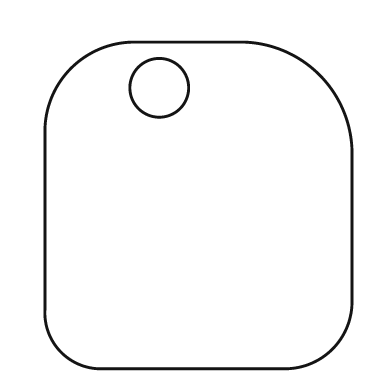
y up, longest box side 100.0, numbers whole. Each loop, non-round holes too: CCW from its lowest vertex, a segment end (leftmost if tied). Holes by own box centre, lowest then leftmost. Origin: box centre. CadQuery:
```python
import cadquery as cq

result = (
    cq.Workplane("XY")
    .moveTo(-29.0, -50.0)
    .lineTo(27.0, -50.0)
    .threePointArc((41.0, -44.0), (47.0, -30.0))
    .lineTo(47.0, 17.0)
    .threePointArc((37.0, 40.0), (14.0, 50.0))
    .lineTo(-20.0, 50.0)
    .threePointArc((-39.0, 42.0), (-47.0, 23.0))
    .lineTo(-47.0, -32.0)
    .threePointArc((-42.0, -45.0), (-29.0, -50.0))
    .close()
    .moveTo(-12.0, 36.0)
    .circle(9.0)
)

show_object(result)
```